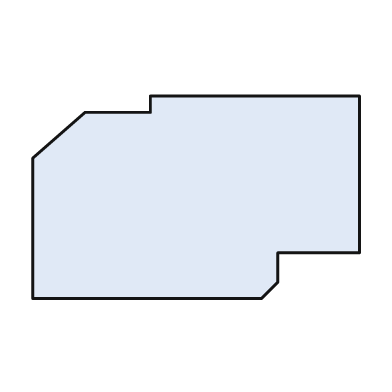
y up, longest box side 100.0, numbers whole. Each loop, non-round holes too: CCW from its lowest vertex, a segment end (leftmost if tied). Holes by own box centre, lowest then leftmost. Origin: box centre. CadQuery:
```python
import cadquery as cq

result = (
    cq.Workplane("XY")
    .moveTo(-50.0, -31.0)
    .lineTo(20.0, -31.0)
    .lineTo(25.0, -26.0)
    .lineTo(25.0, -17.0)
    .lineTo(50.0, -17.0)
    .lineTo(50.0, 31.0)
    .lineTo(-14.0, 31.0)
    .lineTo(-14.0, 26.0)
    .lineTo(-34.0, 26.0)
    .lineTo(-50.0, 12.0)
    .close()
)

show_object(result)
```